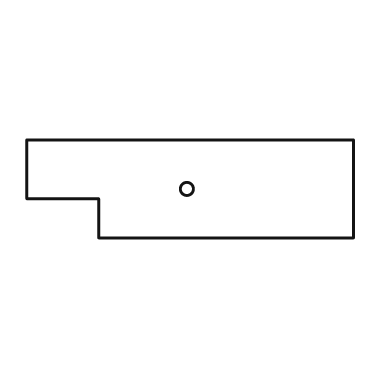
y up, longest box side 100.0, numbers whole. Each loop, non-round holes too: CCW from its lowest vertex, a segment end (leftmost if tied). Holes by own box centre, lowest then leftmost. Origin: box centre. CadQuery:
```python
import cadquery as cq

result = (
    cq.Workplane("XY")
    .moveTo(-28.0, -15.0)
    .lineTo(50.0, -15.0)
    .lineTo(50.0, 15.0)
    .lineTo(-50.0, 15.0)
    .lineTo(-50.0, -3.0)
    .lineTo(-28.0, -3.0)
    .close()
    .moveTo(-1.0, 0.0)
    .circle(2.0)
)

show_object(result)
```